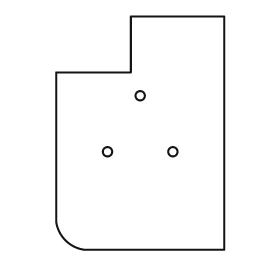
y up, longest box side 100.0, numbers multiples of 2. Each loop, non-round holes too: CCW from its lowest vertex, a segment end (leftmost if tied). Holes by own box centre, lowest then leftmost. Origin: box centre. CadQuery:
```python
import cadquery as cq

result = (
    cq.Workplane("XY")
    .moveTo(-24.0, -50.0)
    .lineTo(36.0, -50.0)
    .lineTo(36.0, 50.0)
    .lineTo(-4.0, 50.0)
    .lineTo(-4.0, 26.0)
    .lineTo(-36.0, 26.0)
    .lineTo(-36.0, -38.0)
    .threePointArc((-32.0, -46.0), (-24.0, -50.0))
    .close()
    .moveTo(-14.0, -8.0)
    .circle(2.0)
    .moveTo(14.0, -8.0)
    .circle(2.0)
    .moveTo(0.0, 16.0)
    .circle(2.0)
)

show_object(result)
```